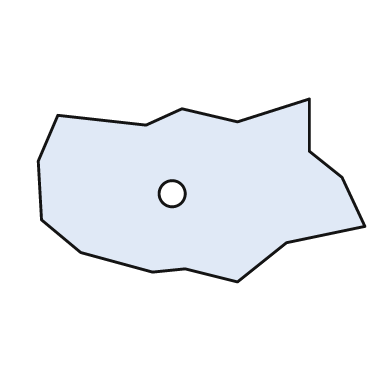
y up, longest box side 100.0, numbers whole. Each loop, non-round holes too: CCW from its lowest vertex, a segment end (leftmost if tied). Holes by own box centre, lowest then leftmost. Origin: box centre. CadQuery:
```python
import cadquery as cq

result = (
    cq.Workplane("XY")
    .moveTo(11.0, -28.0)
    .lineTo(26.0, -16.0)
    .lineTo(50.0, -11.0)
    .lineTo(43.0, 4.0)
    .lineTo(33.0, 12.0)
    .lineTo(33.0, 28.0)
    .lineTo(11.0, 21.0)
    .lineTo(-6.0, 25.0)
    .lineTo(-17.0, 20.0)
    .lineTo(-44.0, 23.0)
    .lineTo(-50.0, 9.0)
    .lineTo(-49.0, -9.0)
    .lineTo(-37.0, -19.0)
    .lineTo(-15.0, -25.0)
    .lineTo(-5.0, -24.0)
    .close()
    .moveTo(-9.0, -1.0)
    .circle(4.0)
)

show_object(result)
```